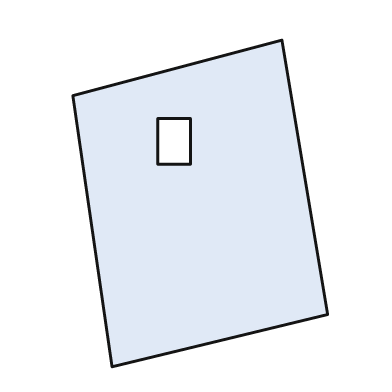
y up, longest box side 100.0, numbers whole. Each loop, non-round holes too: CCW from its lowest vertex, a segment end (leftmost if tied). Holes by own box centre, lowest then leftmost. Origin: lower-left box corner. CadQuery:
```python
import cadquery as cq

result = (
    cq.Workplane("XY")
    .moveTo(12.0, 0.0)
    .lineTo(78.0, 16.0)
    .lineTo(64.0, 100.0)
    .lineTo(0.0, 83.0)
    .close()
    .moveTo(26.0, 62.0)
    .lineTo(36.0, 62.0)
    .lineTo(36.0, 76.0)
    .lineTo(26.0, 76.0)
    .close()
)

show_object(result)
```